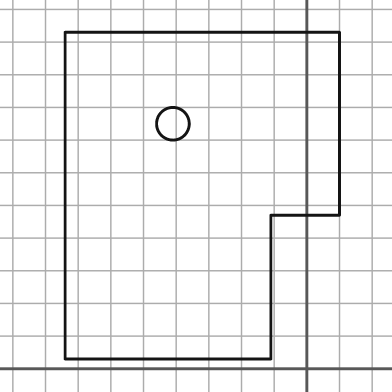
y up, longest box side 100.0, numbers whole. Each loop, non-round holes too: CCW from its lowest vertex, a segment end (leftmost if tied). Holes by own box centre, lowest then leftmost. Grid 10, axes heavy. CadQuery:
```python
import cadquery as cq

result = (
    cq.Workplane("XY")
    .moveTo(-74.0, 3.0)
    .lineTo(-11.0, 3.0)
    .lineTo(-11.0, 47.0)
    .lineTo(10.0, 47.0)
    .lineTo(10.0, 103.0)
    .lineTo(-74.0, 103.0)
    .close()
    .moveTo(-41.0, 75.0)
    .circle(5.0)
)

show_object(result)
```